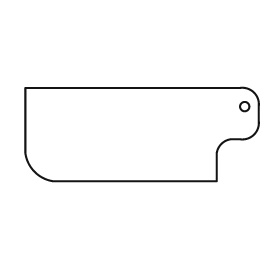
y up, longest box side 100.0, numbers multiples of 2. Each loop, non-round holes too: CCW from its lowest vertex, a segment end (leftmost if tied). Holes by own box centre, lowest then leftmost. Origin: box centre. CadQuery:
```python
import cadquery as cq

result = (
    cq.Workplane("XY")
    .moveTo(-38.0, -20.0)
    .lineTo(32.0, -20.0)
    .lineTo(32.0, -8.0)
    .threePointArc((34.0, -4.0), (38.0, -2.0))
    .lineTo(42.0, -2.0)
    .threePointArc((48.0, 0.0), (50.0, 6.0))
    .lineTo(50.0, 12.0)
    .threePointArc((48.0, 18.0), (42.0, 20.0))
    .lineTo(-50.0, 20.0)
    .lineTo(-50.0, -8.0)
    .threePointArc((-46.0, -16.0), (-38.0, -20.0))
    .close()
    .moveTo(44.0, 12.0)
    .circle(2.0)
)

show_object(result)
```